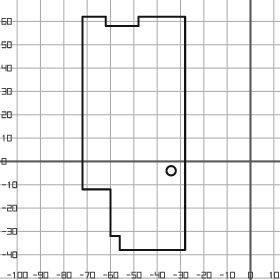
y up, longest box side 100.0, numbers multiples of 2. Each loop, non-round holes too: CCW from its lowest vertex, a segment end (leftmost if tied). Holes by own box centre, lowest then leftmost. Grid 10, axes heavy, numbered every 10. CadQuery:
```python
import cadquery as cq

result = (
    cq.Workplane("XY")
    .moveTo(-56.0, -38.0)
    .lineTo(-28.0, -38.0)
    .lineTo(-28.0, 62.0)
    .lineTo(-48.0, 62.0)
    .lineTo(-48.0, 58.0)
    .lineTo(-62.0, 58.0)
    .lineTo(-62.0, 62.0)
    .lineTo(-72.0, 62.0)
    .lineTo(-72.0, -12.0)
    .lineTo(-60.0, -12.0)
    .lineTo(-60.0, -32.0)
    .lineTo(-56.0, -32.0)
    .close()
    .moveTo(-34.0, -4.0)
    .circle(2.0)
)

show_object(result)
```